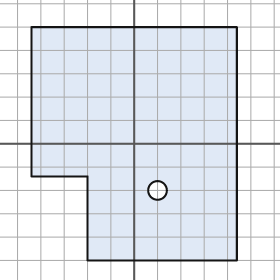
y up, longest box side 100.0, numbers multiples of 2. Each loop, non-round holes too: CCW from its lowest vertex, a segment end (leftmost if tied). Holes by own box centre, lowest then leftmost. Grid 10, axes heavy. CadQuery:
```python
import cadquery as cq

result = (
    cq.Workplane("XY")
    .moveTo(-20.0, -50.0)
    .lineTo(44.0, -50.0)
    .lineTo(44.0, 50.0)
    .lineTo(-44.0, 50.0)
    .lineTo(-44.0, -14.0)
    .lineTo(-20.0, -14.0)
    .close()
    .moveTo(10.0, -20.0)
    .circle(4.0)
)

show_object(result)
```